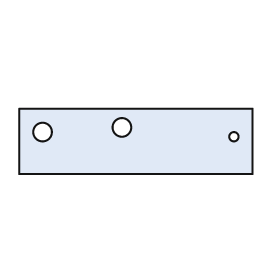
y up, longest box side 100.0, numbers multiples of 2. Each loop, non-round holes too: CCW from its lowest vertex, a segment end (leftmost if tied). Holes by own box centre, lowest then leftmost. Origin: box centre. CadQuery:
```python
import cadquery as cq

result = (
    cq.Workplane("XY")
    .moveTo(-50.0, -14.0)
    .lineTo(50.0, -14.0)
    .lineTo(50.0, 14.0)
    .lineTo(-50.0, 14.0)
    .close()
    .moveTo(42.0, 2.0)
    .circle(2.0)
    .moveTo(-40.0, 4.0)
    .circle(4.0)
    .moveTo(-6.0, 6.0)
    .circle(4.0)
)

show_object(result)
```